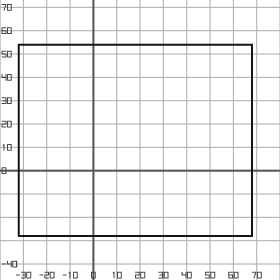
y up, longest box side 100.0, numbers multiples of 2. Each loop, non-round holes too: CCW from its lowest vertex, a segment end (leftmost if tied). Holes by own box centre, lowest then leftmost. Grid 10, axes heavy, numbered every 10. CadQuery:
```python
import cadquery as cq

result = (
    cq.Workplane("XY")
    .moveTo(-32.0, -28.0)
    .lineTo(68.0, -28.0)
    .lineTo(68.0, 54.0)
    .lineTo(-32.0, 54.0)
    .close()
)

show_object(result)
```